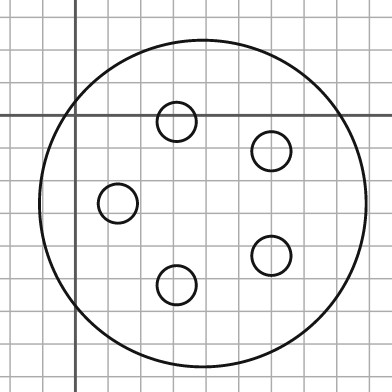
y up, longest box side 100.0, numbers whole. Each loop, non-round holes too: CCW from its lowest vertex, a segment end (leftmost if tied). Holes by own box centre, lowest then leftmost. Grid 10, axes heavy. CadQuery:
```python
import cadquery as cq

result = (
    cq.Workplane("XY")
    .moveTo(39.0, -27.0)
    .circle(50.0)
    .moveTo(31.0, -52.0)
    .circle(6.0)
    .moveTo(60.0, -43.0)
    .circle(6.0)
    .moveTo(13.0, -27.0)
    .circle(6.0)
    .moveTo(60.0, -11.0)
    .circle(6.0)
    .moveTo(31.0, -2.0)
    .circle(6.0)
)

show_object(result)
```